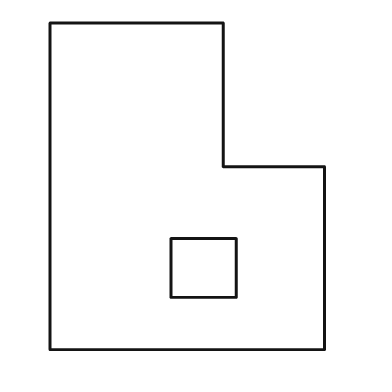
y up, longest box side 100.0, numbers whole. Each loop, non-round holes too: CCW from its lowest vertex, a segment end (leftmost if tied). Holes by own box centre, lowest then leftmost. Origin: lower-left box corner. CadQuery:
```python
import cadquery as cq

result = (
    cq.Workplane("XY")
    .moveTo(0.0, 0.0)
    .lineTo(84.0, 0.0)
    .lineTo(84.0, 56.0)
    .lineTo(53.0, 56.0)
    .lineTo(53.0, 100.0)
    .lineTo(0.0, 100.0)
    .close()
    .moveTo(37.0, 16.0)
    .lineTo(57.0, 16.0)
    .lineTo(57.0, 34.0)
    .lineTo(37.0, 34.0)
    .close()
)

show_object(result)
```